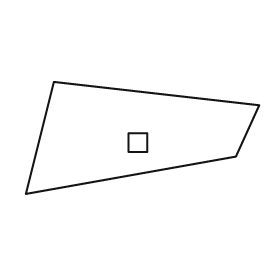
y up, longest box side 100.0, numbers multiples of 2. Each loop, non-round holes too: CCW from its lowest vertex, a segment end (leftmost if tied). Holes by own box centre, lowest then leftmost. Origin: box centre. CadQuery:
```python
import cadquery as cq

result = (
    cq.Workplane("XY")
    .moveTo(-50.0, -24.0)
    .lineTo(40.0, -8.0)
    .lineTo(50.0, 14.0)
    .lineTo(-38.0, 24.0)
    .close()
    .moveTo(-6.0, -6.0)
    .lineTo(2.0, -6.0)
    .lineTo(2.0, 2.0)
    .lineTo(-6.0, 2.0)
    .close()
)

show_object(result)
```